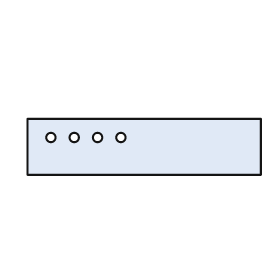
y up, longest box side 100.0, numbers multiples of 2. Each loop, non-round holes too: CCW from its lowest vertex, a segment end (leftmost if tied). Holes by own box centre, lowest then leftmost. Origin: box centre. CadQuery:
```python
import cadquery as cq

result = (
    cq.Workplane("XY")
    .moveTo(-50.0, -12.0)
    .lineTo(50.0, -12.0)
    .lineTo(50.0, 12.0)
    .lineTo(-50.0, 12.0)
    .close()
    .moveTo(-40.0, 4.0)
    .circle(2.0)
    .moveTo(-30.0, 4.0)
    .circle(2.0)
    .moveTo(-20.0, 4.0)
    .circle(2.0)
    .moveTo(-10.0, 4.0)
    .circle(2.0)
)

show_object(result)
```